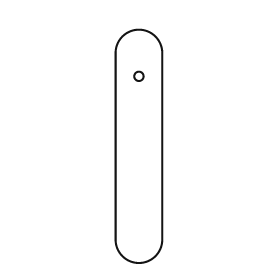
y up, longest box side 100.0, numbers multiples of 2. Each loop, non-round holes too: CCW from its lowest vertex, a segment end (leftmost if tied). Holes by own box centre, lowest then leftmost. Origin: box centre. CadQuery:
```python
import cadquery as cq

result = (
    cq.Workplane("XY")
    .moveTo(-10.0, -40.0)
    .threePointArc((0.0, -50.0), (10.0, -40.0))
    .lineTo(10.0, 40.0)
    .threePointArc((0.0, 50.0), (-10.0, 40.0))
    .close()
    .moveTo(0.0, 30.0)
    .circle(2.0)
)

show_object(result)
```